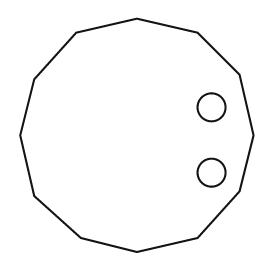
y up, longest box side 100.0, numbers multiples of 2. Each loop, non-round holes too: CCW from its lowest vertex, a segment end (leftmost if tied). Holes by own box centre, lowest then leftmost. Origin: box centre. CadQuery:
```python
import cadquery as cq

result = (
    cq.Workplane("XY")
    .moveTo(0.0, -50.0)
    .lineTo(26.0, -44.0)
    .lineTo(44.0, -24.0)
    .lineTo(50.0, 0.0)
    .lineTo(44.0, 26.0)
    .lineTo(26.0, 44.0)
    .lineTo(0.0, 50.0)
    .lineTo(-26.0, 44.0)
    .lineTo(-44.0, 24.0)
    .lineTo(-50.0, 0.0)
    .lineTo(-44.0, -26.0)
    .lineTo(-24.0, -44.0)
    .close()
    .moveTo(32.0, -16.0)
    .circle(6.0)
    .moveTo(32.0, 12.0)
    .circle(6.0)
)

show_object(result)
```